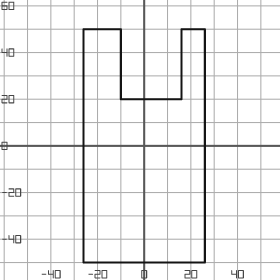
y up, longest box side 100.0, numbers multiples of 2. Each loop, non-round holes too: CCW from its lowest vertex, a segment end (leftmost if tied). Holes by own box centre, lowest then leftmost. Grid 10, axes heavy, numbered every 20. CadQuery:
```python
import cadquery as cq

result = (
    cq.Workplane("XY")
    .moveTo(-26.0, -50.0)
    .lineTo(26.0, -50.0)
    .lineTo(26.0, 50.0)
    .lineTo(16.0, 50.0)
    .lineTo(16.0, 20.0)
    .lineTo(-10.0, 20.0)
    .lineTo(-10.0, 50.0)
    .lineTo(-26.0, 50.0)
    .close()
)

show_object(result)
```